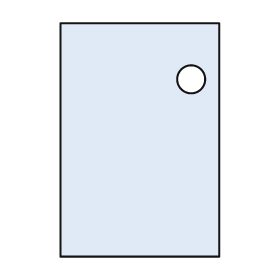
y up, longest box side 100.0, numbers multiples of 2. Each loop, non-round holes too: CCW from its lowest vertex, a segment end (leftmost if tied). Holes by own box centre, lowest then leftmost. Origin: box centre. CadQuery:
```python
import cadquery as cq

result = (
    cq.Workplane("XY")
    .moveTo(-34.0, -50.0)
    .lineTo(34.0, -50.0)
    .lineTo(34.0, 50.0)
    .lineTo(-34.0, 50.0)
    .close()
    .moveTo(22.0, 26.0)
    .circle(6.0)
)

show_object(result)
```